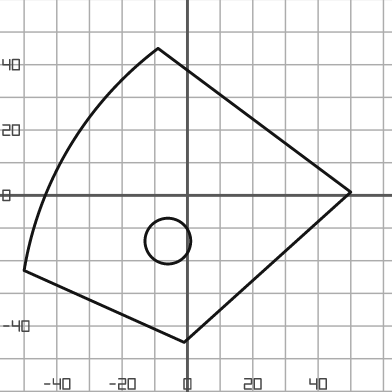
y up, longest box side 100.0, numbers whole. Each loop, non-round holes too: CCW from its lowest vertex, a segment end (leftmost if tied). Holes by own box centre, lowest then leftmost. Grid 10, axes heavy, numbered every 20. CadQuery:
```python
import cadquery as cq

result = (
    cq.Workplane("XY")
    .moveTo(-1.0, -45.0)
    .lineTo(50.0, 1.0)
    .lineTo(-9.0, 45.0)
    .threePointArc((-36.0, 15.0), (-50.0, -23.0))
    .close()
    .moveTo(-6.0, -14.0)
    .circle(7.0)
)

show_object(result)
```